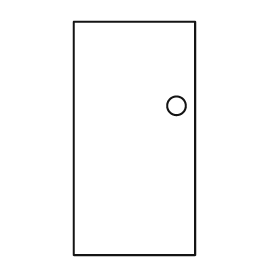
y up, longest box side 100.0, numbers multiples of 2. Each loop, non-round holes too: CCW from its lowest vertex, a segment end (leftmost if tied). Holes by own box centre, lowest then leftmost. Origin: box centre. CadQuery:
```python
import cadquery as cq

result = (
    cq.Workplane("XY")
    .moveTo(-26.0, -50.0)
    .lineTo(26.0, -50.0)
    .lineTo(26.0, 50.0)
    .lineTo(-26.0, 50.0)
    .close()
    .moveTo(18.0, 14.0)
    .circle(4.0)
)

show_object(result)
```